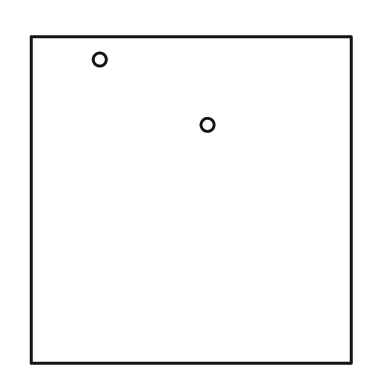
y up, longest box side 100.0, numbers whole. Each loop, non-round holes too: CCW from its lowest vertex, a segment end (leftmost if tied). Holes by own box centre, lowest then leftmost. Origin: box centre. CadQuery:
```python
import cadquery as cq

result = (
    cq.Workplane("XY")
    .moveTo(-49.0, -50.0)
    .lineTo(49.0, -50.0)
    .lineTo(49.0, 50.0)
    .lineTo(-49.0, 50.0)
    .close()
    .moveTo(5.0, 23.0)
    .circle(2.0)
    .moveTo(-28.0, 43.0)
    .circle(2.0)
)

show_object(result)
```